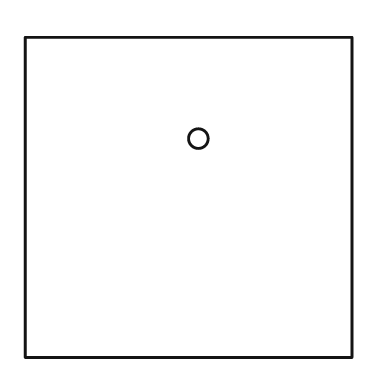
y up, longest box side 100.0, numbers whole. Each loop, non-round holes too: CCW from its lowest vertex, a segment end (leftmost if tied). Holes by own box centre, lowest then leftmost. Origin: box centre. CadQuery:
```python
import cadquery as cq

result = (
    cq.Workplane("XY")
    .moveTo(-50.0, -49.0)
    .lineTo(50.0, -49.0)
    .lineTo(50.0, 49.0)
    .lineTo(-50.0, 49.0)
    .close()
    .moveTo(3.0, 18.0)
    .circle(3.0)
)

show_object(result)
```